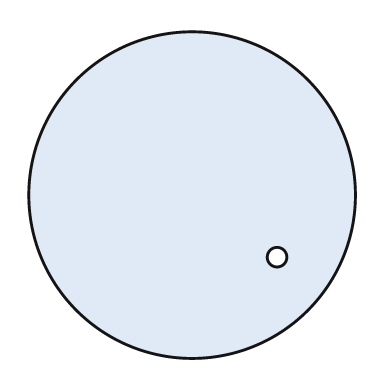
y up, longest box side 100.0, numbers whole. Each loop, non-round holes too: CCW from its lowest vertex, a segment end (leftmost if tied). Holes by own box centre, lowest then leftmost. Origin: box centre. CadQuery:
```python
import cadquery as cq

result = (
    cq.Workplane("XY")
    .moveTo(0.0, 0.0)
    .circle(50.0)
    .moveTo(26.0, -19.0)
    .circle(3.0)
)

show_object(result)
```